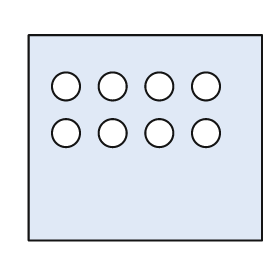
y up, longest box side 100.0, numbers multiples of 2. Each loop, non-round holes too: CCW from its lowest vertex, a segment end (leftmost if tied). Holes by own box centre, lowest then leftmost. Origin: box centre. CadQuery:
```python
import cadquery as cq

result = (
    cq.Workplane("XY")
    .moveTo(-50.0, -44.0)
    .lineTo(50.0, -44.0)
    .lineTo(50.0, 44.0)
    .lineTo(-50.0, 44.0)
    .close()
    .moveTo(-34.0, 2.0)
    .circle(6.0)
    .moveTo(-14.0, 2.0)
    .circle(6.0)
    .moveTo(6.0, 2.0)
    .circle(6.0)
    .moveTo(26.0, 2.0)
    .circle(6.0)
    .moveTo(-34.0, 22.0)
    .circle(6.0)
    .moveTo(-14.0, 22.0)
    .circle(6.0)
    .moveTo(6.0, 22.0)
    .circle(6.0)
    .moveTo(26.0, 22.0)
    .circle(6.0)
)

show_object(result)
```